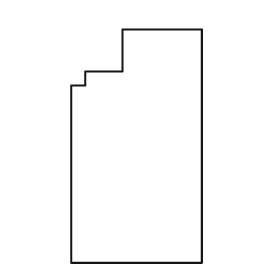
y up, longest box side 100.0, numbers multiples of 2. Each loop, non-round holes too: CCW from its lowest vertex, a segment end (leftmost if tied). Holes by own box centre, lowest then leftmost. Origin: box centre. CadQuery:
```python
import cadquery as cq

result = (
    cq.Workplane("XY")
    .moveTo(-28.0, -50.0)
    .lineTo(28.0, -50.0)
    .lineTo(28.0, 50.0)
    .lineTo(-6.0, 50.0)
    .lineTo(-6.0, 32.0)
    .lineTo(-22.0, 32.0)
    .lineTo(-22.0, 26.0)
    .lineTo(-28.0, 26.0)
    .close()
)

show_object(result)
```